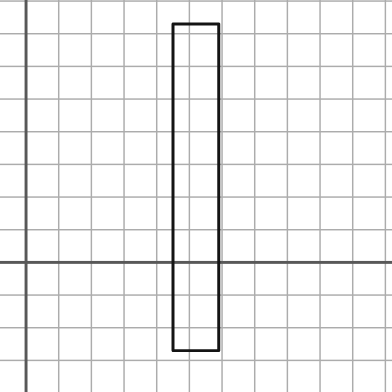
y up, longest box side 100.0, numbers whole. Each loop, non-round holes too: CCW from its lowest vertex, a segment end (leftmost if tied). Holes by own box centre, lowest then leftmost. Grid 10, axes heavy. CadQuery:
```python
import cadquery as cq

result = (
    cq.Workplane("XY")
    .moveTo(45.0, -27.0)
    .lineTo(59.0, -27.0)
    .lineTo(59.0, 73.0)
    .lineTo(45.0, 73.0)
    .close()
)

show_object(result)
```